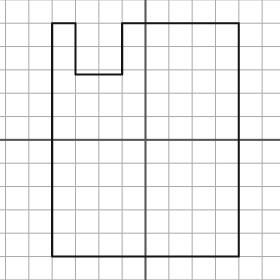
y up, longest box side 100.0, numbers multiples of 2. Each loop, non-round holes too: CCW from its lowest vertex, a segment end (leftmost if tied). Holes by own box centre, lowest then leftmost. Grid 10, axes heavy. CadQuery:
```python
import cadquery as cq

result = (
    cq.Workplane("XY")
    .moveTo(-40.0, -50.0)
    .lineTo(40.0, -50.0)
    .lineTo(40.0, 50.0)
    .lineTo(-10.0, 50.0)
    .lineTo(-10.0, 28.0)
    .lineTo(-30.0, 28.0)
    .lineTo(-30.0, 50.0)
    .lineTo(-40.0, 50.0)
    .close()
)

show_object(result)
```